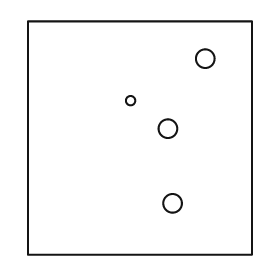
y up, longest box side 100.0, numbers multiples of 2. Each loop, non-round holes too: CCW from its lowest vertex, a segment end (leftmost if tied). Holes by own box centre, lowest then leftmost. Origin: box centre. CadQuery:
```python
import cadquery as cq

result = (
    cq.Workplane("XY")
    .moveTo(-48.0, -50.0)
    .lineTo(48.0, -50.0)
    .lineTo(48.0, 50.0)
    .lineTo(-48.0, 50.0)
    .close()
    .moveTo(14.0, -28.0)
    .circle(4.0)
    .moveTo(12.0, 4.0)
    .circle(4.0)
    .moveTo(-4.0, 16.0)
    .circle(2.0)
    .moveTo(28.0, 34.0)
    .circle(4.0)
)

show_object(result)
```